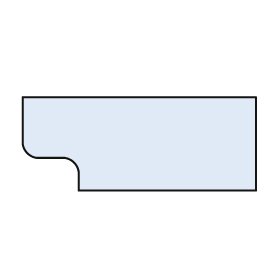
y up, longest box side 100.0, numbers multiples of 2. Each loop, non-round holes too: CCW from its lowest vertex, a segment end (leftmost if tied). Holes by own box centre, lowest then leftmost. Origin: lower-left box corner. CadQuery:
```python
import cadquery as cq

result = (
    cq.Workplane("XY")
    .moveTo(24.0, 0.0)
    .lineTo(100.0, 0.0)
    .lineTo(100.0, 40.0)
    .lineTo(0.0, 40.0)
    .lineTo(0.0, 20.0)
    .threePointArc((2.0, 16.0), (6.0, 14.0))
    .lineTo(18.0, 14.0)
    .threePointArc((22.0, 12.0), (24.0, 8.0))
    .close()
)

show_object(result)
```